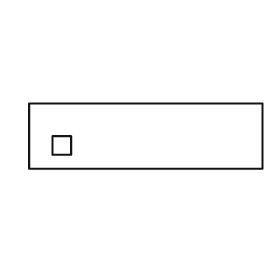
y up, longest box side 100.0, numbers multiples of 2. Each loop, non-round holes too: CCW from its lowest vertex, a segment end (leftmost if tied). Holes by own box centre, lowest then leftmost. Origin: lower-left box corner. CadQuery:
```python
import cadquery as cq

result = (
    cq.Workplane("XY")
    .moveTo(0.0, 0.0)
    .lineTo(100.0, 0.0)
    .lineTo(100.0, 28.0)
    .lineTo(0.0, 28.0)
    .close()
    .moveTo(10.0, 6.0)
    .lineTo(18.0, 6.0)
    .lineTo(18.0, 14.0)
    .lineTo(10.0, 14.0)
    .close()
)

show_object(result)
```